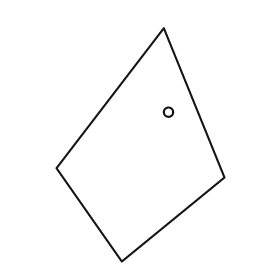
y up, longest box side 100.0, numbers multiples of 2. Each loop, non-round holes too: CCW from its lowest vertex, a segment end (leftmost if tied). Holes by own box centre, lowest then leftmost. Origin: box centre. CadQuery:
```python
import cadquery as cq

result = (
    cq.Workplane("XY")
    .moveTo(-8.0, -50.0)
    .lineTo(36.0, -14.0)
    .lineTo(10.0, 50.0)
    .lineTo(-36.0, -10.0)
    .close()
    .moveTo(12.0, 14.0)
    .circle(2.0)
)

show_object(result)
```